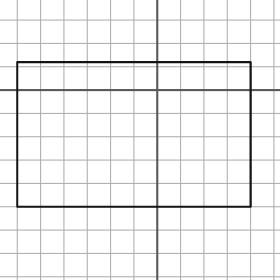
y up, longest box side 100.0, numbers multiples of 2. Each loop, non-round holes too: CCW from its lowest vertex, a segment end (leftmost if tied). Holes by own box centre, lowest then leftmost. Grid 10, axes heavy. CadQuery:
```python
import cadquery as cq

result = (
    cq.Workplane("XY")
    .moveTo(-60.0, -50.0)
    .lineTo(40.0, -50.0)
    .lineTo(40.0, 12.0)
    .lineTo(-60.0, 12.0)
    .close()
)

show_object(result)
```